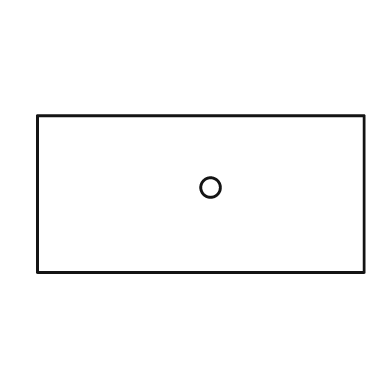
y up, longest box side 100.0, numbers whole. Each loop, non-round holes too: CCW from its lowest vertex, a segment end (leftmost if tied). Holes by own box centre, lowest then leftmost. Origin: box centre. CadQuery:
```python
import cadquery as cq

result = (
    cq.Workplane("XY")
    .moveTo(-50.0, -24.0)
    .lineTo(50.0, -24.0)
    .lineTo(50.0, 24.0)
    .lineTo(-50.0, 24.0)
    .close()
    .moveTo(3.0, 2.0)
    .circle(3.0)
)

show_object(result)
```